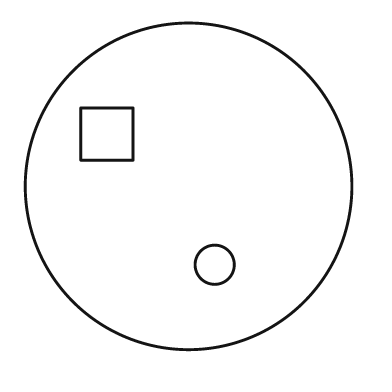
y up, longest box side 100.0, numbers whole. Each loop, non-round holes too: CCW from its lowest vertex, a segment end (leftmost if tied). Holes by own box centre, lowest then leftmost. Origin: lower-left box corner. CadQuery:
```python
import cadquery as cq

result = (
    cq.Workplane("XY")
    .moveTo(50.0, 50.0)
    .circle(50.0)
    .moveTo(58.0, 26.0)
    .circle(6.0)
    .moveTo(17.0, 58.0)
    .lineTo(33.0, 58.0)
    .lineTo(33.0, 74.0)
    .lineTo(17.0, 74.0)
    .close()
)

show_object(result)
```